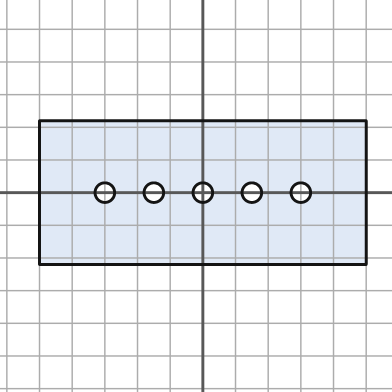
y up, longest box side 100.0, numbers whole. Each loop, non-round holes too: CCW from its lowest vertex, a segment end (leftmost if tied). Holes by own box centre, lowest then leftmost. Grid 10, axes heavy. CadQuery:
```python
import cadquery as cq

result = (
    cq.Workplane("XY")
    .moveTo(-50.0, -22.0)
    .lineTo(50.0, -22.0)
    .lineTo(50.0, 22.0)
    .lineTo(-50.0, 22.0)
    .close()
    .moveTo(-30.0, 0.0)
    .circle(3.0)
    .moveTo(-15.0, 0.0)
    .circle(3.0)
    .moveTo(0.0, 0.0)
    .circle(3.0)
    .moveTo(15.0, 0.0)
    .circle(3.0)
    .moveTo(30.0, 0.0)
    .circle(3.0)
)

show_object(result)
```